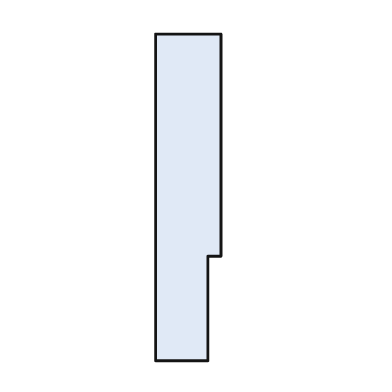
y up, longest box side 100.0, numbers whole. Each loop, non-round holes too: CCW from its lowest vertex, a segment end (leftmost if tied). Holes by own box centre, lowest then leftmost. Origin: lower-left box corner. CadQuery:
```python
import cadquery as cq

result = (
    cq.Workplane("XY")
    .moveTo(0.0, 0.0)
    .lineTo(16.0, 0.0)
    .lineTo(16.0, 32.0)
    .lineTo(20.0, 32.0)
    .lineTo(20.0, 100.0)
    .lineTo(0.0, 100.0)
    .close()
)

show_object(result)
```